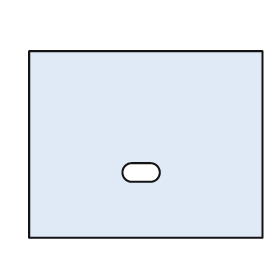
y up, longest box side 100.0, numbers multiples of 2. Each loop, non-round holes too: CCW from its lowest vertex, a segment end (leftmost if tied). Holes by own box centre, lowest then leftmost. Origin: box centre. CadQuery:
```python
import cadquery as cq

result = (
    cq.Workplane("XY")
    .moveTo(-50.0, -40.0)
    .lineTo(50.0, -40.0)
    .lineTo(50.0, 40.0)
    .lineTo(-50.0, 40.0)
    .close()
    .moveTo(-6.0, -16.0)
    .lineTo(2.0, -16.0)
    .threePointArc((6.0, -12.0), (2.0, -8.0))
    .lineTo(-6.0, -8.0)
    .threePointArc((-10.0, -12.0), (-6.0, -16.0))
    .close()
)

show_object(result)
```